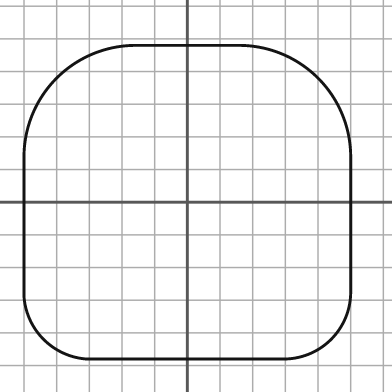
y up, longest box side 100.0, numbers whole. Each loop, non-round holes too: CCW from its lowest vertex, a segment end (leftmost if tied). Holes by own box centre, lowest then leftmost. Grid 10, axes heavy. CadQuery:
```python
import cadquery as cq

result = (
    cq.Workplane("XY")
    .moveTo(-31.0, -48.0)
    .lineTo(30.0, -48.0)
    .threePointArc((44.0, -42.0), (50.0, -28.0))
    .lineTo(50.0, 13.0)
    .threePointArc((40.0, 38.0), (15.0, 48.0))
    .lineTo(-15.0, 48.0)
    .threePointArc((-40.0, 38.0), (-50.0, 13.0))
    .lineTo(-50.0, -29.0)
    .threePointArc((-44.0, -42.0), (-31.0, -48.0))
    .close()
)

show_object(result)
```